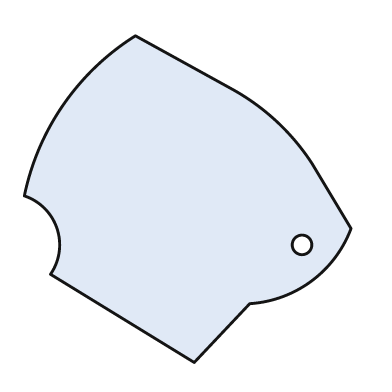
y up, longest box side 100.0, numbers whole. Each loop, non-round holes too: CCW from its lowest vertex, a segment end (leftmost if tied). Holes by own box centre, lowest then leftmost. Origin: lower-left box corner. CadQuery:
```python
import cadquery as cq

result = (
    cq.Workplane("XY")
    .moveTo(52.0, 0.0)
    .lineTo(69.0, 18.0)
    .threePointArc((88.0, 25.0), (100.0, 41.0))
    .lineTo(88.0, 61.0)
    .threePointArc((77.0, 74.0), (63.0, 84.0))
    .lineTo(34.0, 100.0)
    .threePointArc((12.0, 79.0), (0.0, 51.0))
    .threePointArc((10.0, 41.0), (8.0, 27.0))
    .close()
    .moveTo(85.0, 36.0)
    .circle(3.0)
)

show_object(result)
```